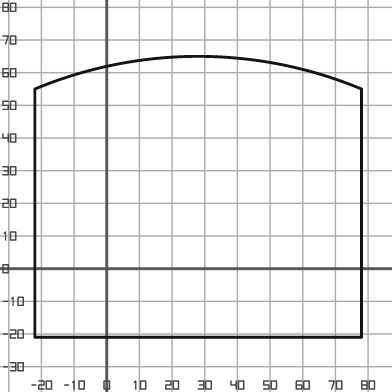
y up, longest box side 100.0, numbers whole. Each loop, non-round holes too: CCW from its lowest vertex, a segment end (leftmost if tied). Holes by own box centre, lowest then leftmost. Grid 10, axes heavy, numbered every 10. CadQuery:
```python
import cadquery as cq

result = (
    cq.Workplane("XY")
    .moveTo(-22.0, -21.0)
    .lineTo(78.0, -21.0)
    .lineTo(78.0, 55.0)
    .threePointArc((28.0, 65.0), (-22.0, 55.0))
    .close()
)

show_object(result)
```